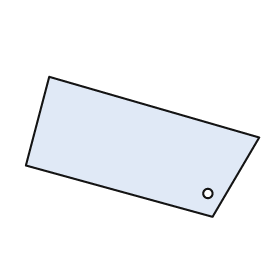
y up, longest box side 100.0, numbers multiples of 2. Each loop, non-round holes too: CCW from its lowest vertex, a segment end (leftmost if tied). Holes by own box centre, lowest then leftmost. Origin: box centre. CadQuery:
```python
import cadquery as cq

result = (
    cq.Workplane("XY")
    .moveTo(30.0, -30.0)
    .lineTo(50.0, 4.0)
    .lineTo(-40.0, 30.0)
    .lineTo(-50.0, -8.0)
    .close()
    .moveTo(28.0, -20.0)
    .circle(2.0)
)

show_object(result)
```